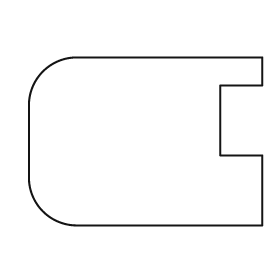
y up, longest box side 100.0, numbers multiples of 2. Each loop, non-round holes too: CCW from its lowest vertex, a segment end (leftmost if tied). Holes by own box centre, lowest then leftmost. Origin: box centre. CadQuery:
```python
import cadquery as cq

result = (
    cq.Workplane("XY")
    .moveTo(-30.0, -36.0)
    .lineTo(50.0, -36.0)
    .lineTo(50.0, -6.0)
    .lineTo(32.0, -6.0)
    .lineTo(32.0, 24.0)
    .lineTo(50.0, 24.0)
    .lineTo(50.0, 36.0)
    .lineTo(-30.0, 36.0)
    .threePointArc((-44.0, 30.0), (-50.0, 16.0))
    .lineTo(-50.0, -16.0)
    .threePointArc((-44.0, -30.0), (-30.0, -36.0))
    .close()
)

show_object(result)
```